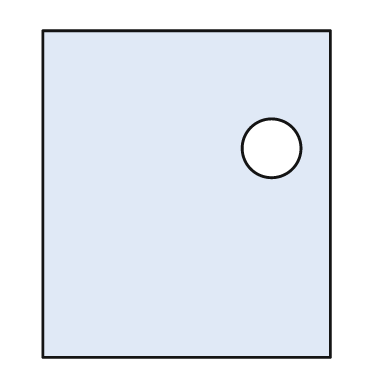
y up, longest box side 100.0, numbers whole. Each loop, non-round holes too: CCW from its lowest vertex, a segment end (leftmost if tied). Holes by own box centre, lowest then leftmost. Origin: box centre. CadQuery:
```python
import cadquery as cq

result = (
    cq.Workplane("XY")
    .moveTo(-44.0, -50.0)
    .lineTo(44.0, -50.0)
    .lineTo(44.0, 50.0)
    .lineTo(-44.0, 50.0)
    .close()
    .moveTo(26.0, 14.0)
    .circle(9.0)
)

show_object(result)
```